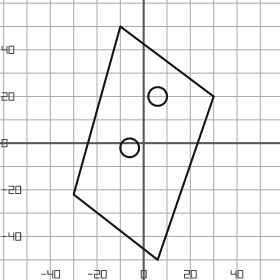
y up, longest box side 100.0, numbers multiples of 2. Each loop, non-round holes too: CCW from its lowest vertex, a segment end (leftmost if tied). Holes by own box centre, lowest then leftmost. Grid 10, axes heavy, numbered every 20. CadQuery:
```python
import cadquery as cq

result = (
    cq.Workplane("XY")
    .moveTo(6.0, -50.0)
    .lineTo(30.0, 20.0)
    .lineTo(-10.0, 50.0)
    .lineTo(-30.0, -22.0)
    .close()
    .moveTo(-6.0, -2.0)
    .circle(4.0)
    .moveTo(6.0, 20.0)
    .circle(4.0)
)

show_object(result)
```